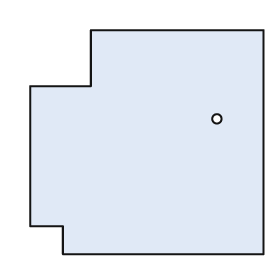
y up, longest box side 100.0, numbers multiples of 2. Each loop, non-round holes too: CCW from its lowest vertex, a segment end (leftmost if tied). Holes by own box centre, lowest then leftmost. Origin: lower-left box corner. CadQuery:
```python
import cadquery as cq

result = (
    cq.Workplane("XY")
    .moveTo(14.0, 0.0)
    .lineTo(100.0, 0.0)
    .lineTo(100.0, 96.0)
    .lineTo(26.0, 96.0)
    .lineTo(26.0, 72.0)
    .lineTo(0.0, 72.0)
    .lineTo(0.0, 12.0)
    .lineTo(14.0, 12.0)
    .close()
    .moveTo(80.0, 58.0)
    .circle(2.0)
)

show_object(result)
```